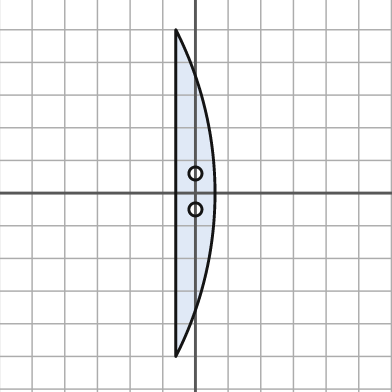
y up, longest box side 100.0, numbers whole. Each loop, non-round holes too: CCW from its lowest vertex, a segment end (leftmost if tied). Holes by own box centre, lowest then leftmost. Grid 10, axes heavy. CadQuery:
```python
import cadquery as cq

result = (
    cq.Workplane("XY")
    .moveTo(-6.0, -50.0)
    .threePointArc((6.0, 0.0), (-6.0, 50.0))
    .close()
    .moveTo(0.0, -5.0)
    .circle(2.0)
    .moveTo(0.0, 6.0)
    .circle(2.0)
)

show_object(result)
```